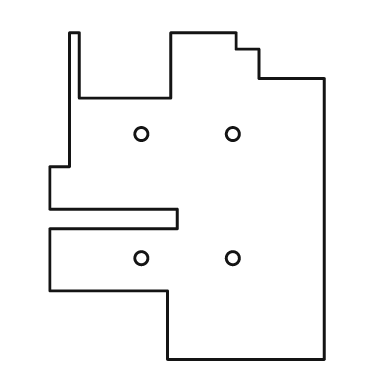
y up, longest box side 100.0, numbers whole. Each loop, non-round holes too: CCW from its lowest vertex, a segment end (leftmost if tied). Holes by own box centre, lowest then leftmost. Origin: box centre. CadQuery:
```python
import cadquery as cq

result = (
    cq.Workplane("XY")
    .moveTo(-6.0, -50.0)
    .lineTo(42.0, -50.0)
    .lineTo(42.0, 36.0)
    .lineTo(22.0, 36.0)
    .lineTo(22.0, 45.0)
    .lineTo(15.0, 45.0)
    .lineTo(15.0, 50.0)
    .lineTo(-5.0, 50.0)
    .lineTo(-5.0, 30.0)
    .lineTo(-33.0, 30.0)
    .lineTo(-33.0, 50.0)
    .lineTo(-36.0, 50.0)
    .lineTo(-36.0, 9.0)
    .lineTo(-42.0, 9.0)
    .lineTo(-42.0, -4.0)
    .lineTo(-3.0, -4.0)
    .lineTo(-3.0, -10.0)
    .lineTo(-42.0, -10.0)
    .lineTo(-42.0, -29.0)
    .lineTo(-6.0, -29.0)
    .close()
    .moveTo(-14.0, -19.0)
    .circle(2.0)
    .moveTo(14.0, -19.0)
    .circle(2.0)
    .moveTo(-14.0, 19.0)
    .circle(2.0)
    .moveTo(14.0, 19.0)
    .circle(2.0)
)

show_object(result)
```